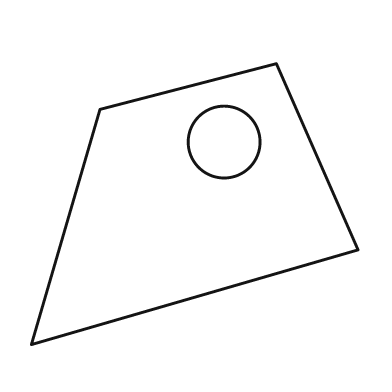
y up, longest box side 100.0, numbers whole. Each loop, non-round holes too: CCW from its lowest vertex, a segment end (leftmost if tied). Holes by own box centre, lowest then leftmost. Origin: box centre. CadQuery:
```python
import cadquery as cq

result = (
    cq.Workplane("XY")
    .moveTo(-50.0, -43.0)
    .lineTo(50.0, -14.0)
    .lineTo(25.0, 43.0)
    .lineTo(-29.0, 29.0)
    .close()
    .moveTo(9.0, 19.0)
    .circle(11.0)
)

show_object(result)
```